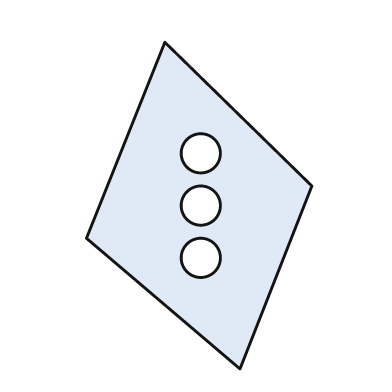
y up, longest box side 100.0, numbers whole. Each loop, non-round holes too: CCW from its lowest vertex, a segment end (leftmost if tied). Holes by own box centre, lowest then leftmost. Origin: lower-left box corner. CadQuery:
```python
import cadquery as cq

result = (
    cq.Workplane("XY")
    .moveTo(47.0, 0.0)
    .lineTo(69.0, 56.0)
    .lineTo(24.0, 100.0)
    .lineTo(0.0, 40.0)
    .close()
    .moveTo(35.0, 34.0)
    .circle(6.0)
    .moveTo(35.0, 50.0)
    .circle(6.0)
    .moveTo(35.0, 66.0)
    .circle(6.0)
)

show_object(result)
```